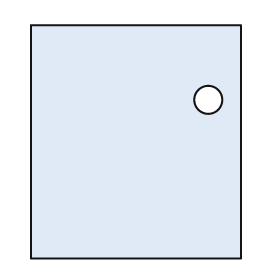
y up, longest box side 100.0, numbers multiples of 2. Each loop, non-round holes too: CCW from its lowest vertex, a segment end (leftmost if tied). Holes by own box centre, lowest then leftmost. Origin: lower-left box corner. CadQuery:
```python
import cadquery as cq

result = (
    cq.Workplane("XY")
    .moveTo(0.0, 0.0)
    .lineTo(90.0, 0.0)
    .lineTo(90.0, 100.0)
    .lineTo(0.0, 100.0)
    .close()
    .moveTo(76.0, 68.0)
    .circle(6.0)
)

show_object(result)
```